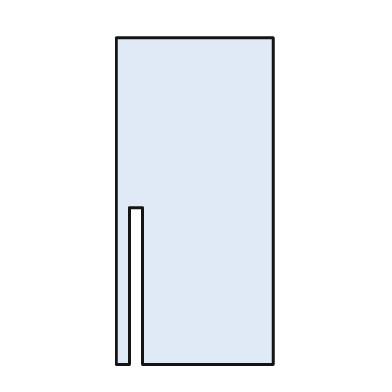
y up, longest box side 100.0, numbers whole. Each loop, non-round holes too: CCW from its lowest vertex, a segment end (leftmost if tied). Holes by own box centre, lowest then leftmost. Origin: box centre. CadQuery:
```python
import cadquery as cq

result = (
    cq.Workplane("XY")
    .moveTo(-24.0, -50.0)
    .lineTo(-20.0, -50.0)
    .lineTo(-20.0, -2.0)
    .lineTo(-16.0, -2.0)
    .lineTo(-16.0, -50.0)
    .lineTo(24.0, -50.0)
    .lineTo(24.0, 50.0)
    .lineTo(-24.0, 50.0)
    .close()
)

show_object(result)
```